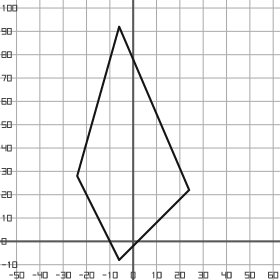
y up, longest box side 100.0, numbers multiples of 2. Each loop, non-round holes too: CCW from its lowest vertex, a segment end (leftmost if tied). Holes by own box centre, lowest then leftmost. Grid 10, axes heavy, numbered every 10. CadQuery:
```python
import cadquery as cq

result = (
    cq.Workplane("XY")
    .moveTo(-6.0, -8.0)
    .lineTo(24.0, 22.0)
    .lineTo(-6.0, 92.0)
    .lineTo(-24.0, 28.0)
    .close()
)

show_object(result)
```